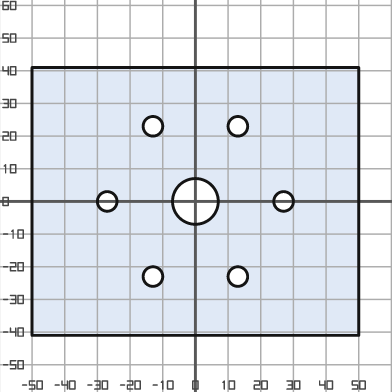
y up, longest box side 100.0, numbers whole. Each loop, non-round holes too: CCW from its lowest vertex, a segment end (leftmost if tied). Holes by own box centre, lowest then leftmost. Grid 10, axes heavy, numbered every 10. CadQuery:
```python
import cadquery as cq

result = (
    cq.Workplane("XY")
    .moveTo(-50.0, -41.0)
    .lineTo(50.0, -41.0)
    .lineTo(50.0, 41.0)
    .lineTo(-50.0, 41.0)
    .close()
    .moveTo(-13.0, -23.0)
    .circle(3.0)
    .moveTo(13.0, -23.0)
    .circle(3.0)
    .moveTo(-27.0, 0.0)
    .circle(3.0)
    .moveTo(0.0, 0.0)
    .circle(7.0)
    .moveTo(27.0, 0.0)
    .circle(3.0)
    .moveTo(-13.0, 23.0)
    .circle(3.0)
    .moveTo(13.0, 23.0)
    .circle(3.0)
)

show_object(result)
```